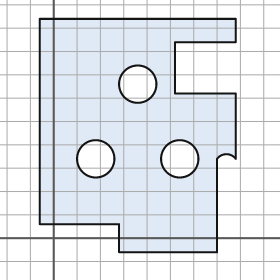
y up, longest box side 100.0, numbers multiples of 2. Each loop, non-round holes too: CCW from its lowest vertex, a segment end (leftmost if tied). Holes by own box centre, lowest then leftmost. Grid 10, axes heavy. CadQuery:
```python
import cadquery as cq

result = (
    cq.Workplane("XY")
    .moveTo(28.0, -6.0)
    .lineTo(70.0, -6.0)
    .lineTo(70.0, 34.0)
    .threePointArc((74.0, 36.0), (78.0, 34.0))
    .lineTo(78.0, 62.0)
    .lineTo(52.0, 62.0)
    .lineTo(52.0, 84.0)
    .lineTo(78.0, 84.0)
    .lineTo(78.0, 94.0)
    .lineTo(-6.0, 94.0)
    .lineTo(-6.0, 6.0)
    .lineTo(28.0, 6.0)
    .close()
    .moveTo(18.0, 34.0)
    .circle(8.0)
    .moveTo(54.0, 34.0)
    .circle(8.0)
    .moveTo(36.0, 66.0)
    .circle(8.0)
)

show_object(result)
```